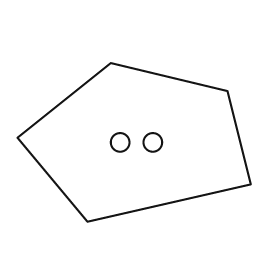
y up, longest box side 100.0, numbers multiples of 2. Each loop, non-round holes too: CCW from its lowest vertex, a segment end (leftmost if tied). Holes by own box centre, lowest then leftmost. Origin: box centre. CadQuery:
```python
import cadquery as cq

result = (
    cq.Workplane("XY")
    .moveTo(-20.0, -34.0)
    .lineTo(50.0, -18.0)
    .lineTo(40.0, 22.0)
    .lineTo(-10.0, 34.0)
    .lineTo(-50.0, 2.0)
    .close()
    .moveTo(-6.0, 0.0)
    .circle(4.0)
    .moveTo(8.0, 0.0)
    .circle(4.0)
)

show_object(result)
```